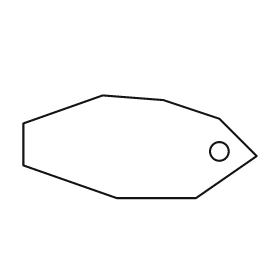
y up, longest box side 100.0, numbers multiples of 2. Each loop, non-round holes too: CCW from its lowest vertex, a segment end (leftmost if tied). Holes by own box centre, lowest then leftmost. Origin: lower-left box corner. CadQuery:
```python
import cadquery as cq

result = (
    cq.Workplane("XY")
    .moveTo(40.0, 0.0)
    .lineTo(74.0, 0.0)
    .lineTo(100.0, 18.0)
    .lineTo(84.0, 34.0)
    .lineTo(60.0, 42.0)
    .lineTo(34.0, 44.0)
    .lineTo(0.0, 32.0)
    .lineTo(0.0, 14.0)
    .close()
    .moveTo(84.0, 20.0)
    .circle(4.0)
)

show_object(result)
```